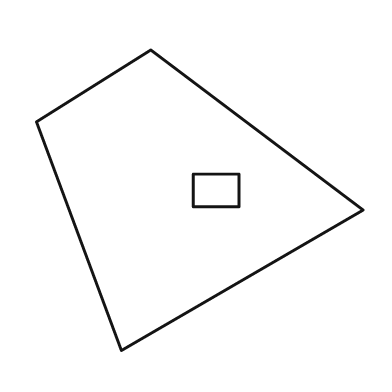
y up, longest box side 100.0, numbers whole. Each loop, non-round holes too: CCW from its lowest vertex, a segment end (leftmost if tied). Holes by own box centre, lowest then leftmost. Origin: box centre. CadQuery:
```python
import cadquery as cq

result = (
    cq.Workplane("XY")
    .moveTo(-24.0, -46.0)
    .lineTo(50.0, -3.0)
    .lineTo(-15.0, 46.0)
    .lineTo(-50.0, 24.0)
    .close()
    .moveTo(-2.0, -2.0)
    .lineTo(12.0, -2.0)
    .lineTo(12.0, 8.0)
    .lineTo(-2.0, 8.0)
    .close()
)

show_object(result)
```